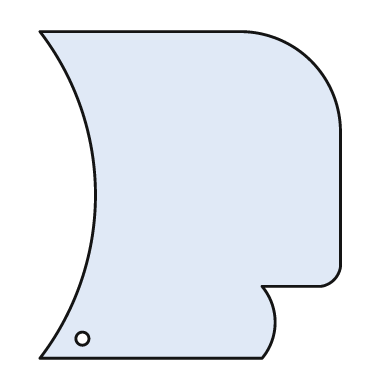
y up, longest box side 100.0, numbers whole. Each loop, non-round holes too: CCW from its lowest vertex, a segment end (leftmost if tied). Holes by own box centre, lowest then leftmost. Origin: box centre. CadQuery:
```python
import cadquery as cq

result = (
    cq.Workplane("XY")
    .moveTo(-46.0, -50.0)
    .lineTo(22.0, -50.0)
    .threePointArc((26.0, -39.0), (22.0, -28.0))
    .lineTo(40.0, -28.0)
    .threePointArc((44.0, -26.0), (46.0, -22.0))
    .lineTo(46.0, 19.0)
    .threePointArc((37.0, 41.0), (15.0, 50.0))
    .lineTo(-46.0, 50.0)
    .threePointArc((-29.0, 0.0), (-46.0, -50.0))
    .close()
    .moveTo(-33.0, -44.0)
    .circle(2.0)
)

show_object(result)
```